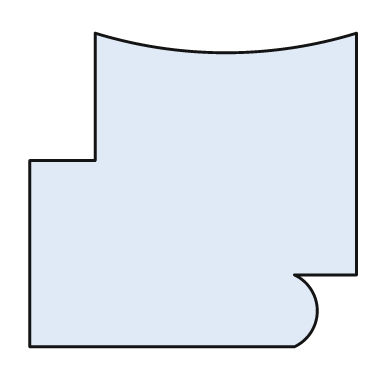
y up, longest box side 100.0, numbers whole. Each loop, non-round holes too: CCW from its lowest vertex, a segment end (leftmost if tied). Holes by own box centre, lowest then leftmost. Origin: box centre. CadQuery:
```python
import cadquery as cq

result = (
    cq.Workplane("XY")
    .moveTo(-50.0, -48.0)
    .lineTo(31.0, -48.0)
    .threePointArc((38.0, -37.0), (31.0, -26.0))
    .lineTo(50.0, -26.0)
    .lineTo(50.0, 48.0)
    .threePointArc((10.0, 42.0), (-30.0, 48.0))
    .lineTo(-30.0, 9.0)
    .lineTo(-50.0, 9.0)
    .close()
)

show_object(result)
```